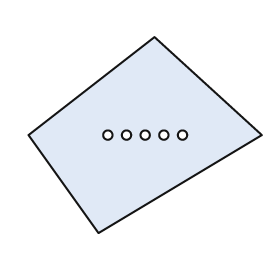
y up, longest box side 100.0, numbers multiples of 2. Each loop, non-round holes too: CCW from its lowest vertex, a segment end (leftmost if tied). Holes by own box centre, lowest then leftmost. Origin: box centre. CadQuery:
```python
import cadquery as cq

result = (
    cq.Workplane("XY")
    .moveTo(-20.0, -42.0)
    .lineTo(50.0, 0.0)
    .lineTo(4.0, 42.0)
    .lineTo(-50.0, 0.0)
    .close()
    .moveTo(-16.0, 0.0)
    .circle(2.0)
    .moveTo(-8.0, 0.0)
    .circle(2.0)
    .moveTo(0.0, 0.0)
    .circle(2.0)
    .moveTo(8.0, 0.0)
    .circle(2.0)
    .moveTo(16.0, 0.0)
    .circle(2.0)
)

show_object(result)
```